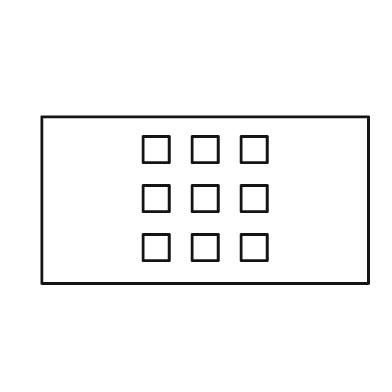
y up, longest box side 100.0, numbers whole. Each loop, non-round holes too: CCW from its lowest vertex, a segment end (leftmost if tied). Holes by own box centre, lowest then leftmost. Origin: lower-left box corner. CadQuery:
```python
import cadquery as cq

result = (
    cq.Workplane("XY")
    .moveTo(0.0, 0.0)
    .lineTo(100.0, 0.0)
    .lineTo(100.0, 51.0)
    .lineTo(0.0, 51.0)
    .close()
    .moveTo(31.0, 7.0)
    .lineTo(39.0, 7.0)
    .lineTo(39.0, 15.0)
    .lineTo(31.0, 15.0)
    .close()
    .moveTo(46.0, 7.0)
    .lineTo(54.0, 7.0)
    .lineTo(54.0, 15.0)
    .lineTo(46.0, 15.0)
    .close()
    .moveTo(61.0, 7.0)
    .lineTo(69.0, 7.0)
    .lineTo(69.0, 15.0)
    .lineTo(61.0, 15.0)
    .close()
    .moveTo(31.0, 22.0)
    .lineTo(39.0, 22.0)
    .lineTo(39.0, 30.0)
    .lineTo(31.0, 30.0)
    .close()
    .moveTo(46.0, 22.0)
    .lineTo(54.0, 22.0)
    .lineTo(54.0, 30.0)
    .lineTo(46.0, 30.0)
    .close()
    .moveTo(61.0, 22.0)
    .lineTo(69.0, 22.0)
    .lineTo(69.0, 30.0)
    .lineTo(61.0, 30.0)
    .close()
    .moveTo(31.0, 37.0)
    .lineTo(39.0, 37.0)
    .lineTo(39.0, 45.0)
    .lineTo(31.0, 45.0)
    .close()
    .moveTo(46.0, 37.0)
    .lineTo(54.0, 37.0)
    .lineTo(54.0, 45.0)
    .lineTo(46.0, 45.0)
    .close()
    .moveTo(61.0, 37.0)
    .lineTo(69.0, 37.0)
    .lineTo(69.0, 45.0)
    .lineTo(61.0, 45.0)
    .close()
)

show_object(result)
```